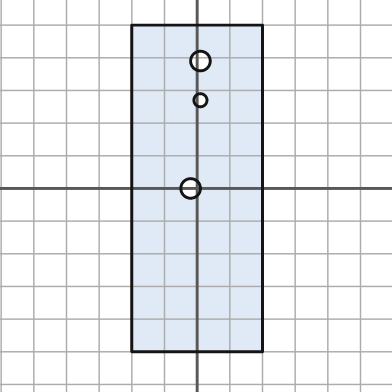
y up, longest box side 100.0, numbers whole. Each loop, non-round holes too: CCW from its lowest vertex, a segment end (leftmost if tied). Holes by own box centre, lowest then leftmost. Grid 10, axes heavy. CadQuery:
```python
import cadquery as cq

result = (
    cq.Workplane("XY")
    .moveTo(-20.0, -50.0)
    .lineTo(20.0, -50.0)
    .lineTo(20.0, 50.0)
    .lineTo(-20.0, 50.0)
    .close()
    .moveTo(-2.0, 0.0)
    .circle(3.0)
    .moveTo(1.0, 27.0)
    .circle(2.0)
    .moveTo(1.0, 39.0)
    .circle(3.0)
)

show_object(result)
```